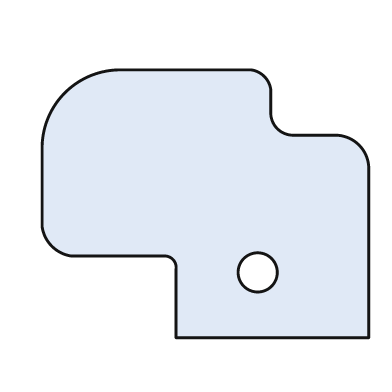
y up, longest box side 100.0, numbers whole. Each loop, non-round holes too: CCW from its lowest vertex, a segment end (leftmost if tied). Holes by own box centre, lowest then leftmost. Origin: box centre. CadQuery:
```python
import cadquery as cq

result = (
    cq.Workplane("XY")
    .moveTo(-9.0, -41.0)
    .lineTo(50.0, -41.0)
    .lineTo(50.0, 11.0)
    .threePointArc((47.0, 18.0), (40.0, 21.0))
    .lineTo(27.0, 21.0)
    .threePointArc((22.0, 23.0), (20.0, 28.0))
    .lineTo(20.0, 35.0)
    .threePointArc((18.0, 39.0), (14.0, 41.0))
    .lineTo(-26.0, 41.0)
    .threePointArc((-43.0, 34.0), (-50.0, 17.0))
    .lineTo(-50.0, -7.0)
    .threePointArc((-47.0, -13.0), (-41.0, -16.0))
    .lineTo(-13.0, -16.0)
    .threePointArc((-10.0, -17.0), (-9.0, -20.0))
    .close()
    .moveTo(16.0, -21.0)
    .circle(6.0)
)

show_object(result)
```